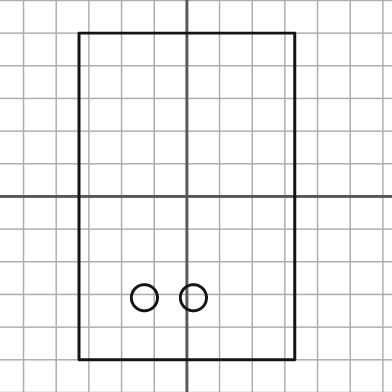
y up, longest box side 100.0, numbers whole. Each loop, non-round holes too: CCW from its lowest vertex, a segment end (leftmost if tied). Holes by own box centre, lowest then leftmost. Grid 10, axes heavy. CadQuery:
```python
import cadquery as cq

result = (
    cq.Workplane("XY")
    .moveTo(-33.0, -50.0)
    .lineTo(33.0, -50.0)
    .lineTo(33.0, 50.0)
    .lineTo(-33.0, 50.0)
    .close()
    .moveTo(-13.0, -31.0)
    .circle(4.0)
    .moveTo(2.0, -31.0)
    .circle(4.0)
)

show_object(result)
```